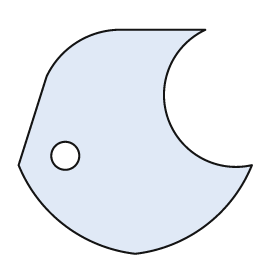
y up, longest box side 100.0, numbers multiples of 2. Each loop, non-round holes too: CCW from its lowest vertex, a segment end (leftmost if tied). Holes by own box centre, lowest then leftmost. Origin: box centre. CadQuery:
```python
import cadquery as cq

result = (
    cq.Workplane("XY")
    .moveTo(0.0, -48.0)
    .threePointArc((30.0, -36.0), (50.0, -10.0))
    .threePointArc((14.0, 10.0), (30.0, 48.0))
    .lineTo(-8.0, 48.0)
    .threePointArc((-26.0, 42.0), (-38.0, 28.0))
    .lineTo(-50.0, -10.0)
    .threePointArc((-30.0, -36.0), (0.0, -48.0))
    .close()
    .moveTo(-30.0, -6.0)
    .circle(6.0)
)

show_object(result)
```